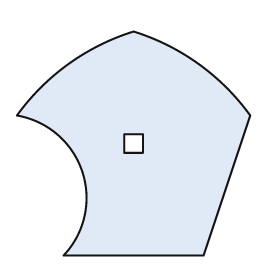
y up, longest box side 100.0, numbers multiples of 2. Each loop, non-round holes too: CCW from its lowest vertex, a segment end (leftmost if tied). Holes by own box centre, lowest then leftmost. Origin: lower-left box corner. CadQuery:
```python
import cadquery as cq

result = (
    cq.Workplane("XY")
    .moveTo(20.0, 0.0)
    .lineTo(80.0, 0.0)
    .lineTo(100.0, 60.0)
    .threePointArc((78.0, 82.0), (50.0, 96.0))
    .threePointArc((22.0, 82.0), (0.0, 60.0))
    .threePointArc((28.0, 36.0), (20.0, 0.0))
    .close()
    .moveTo(46.0, 44.0)
    .lineTo(54.0, 44.0)
    .lineTo(54.0, 52.0)
    .lineTo(46.0, 52.0)
    .close()
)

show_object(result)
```